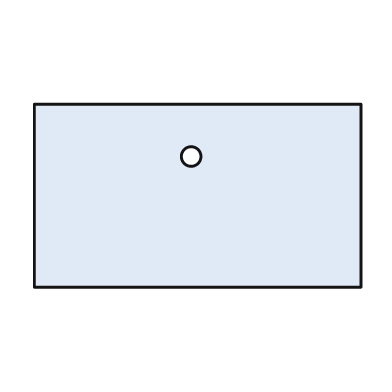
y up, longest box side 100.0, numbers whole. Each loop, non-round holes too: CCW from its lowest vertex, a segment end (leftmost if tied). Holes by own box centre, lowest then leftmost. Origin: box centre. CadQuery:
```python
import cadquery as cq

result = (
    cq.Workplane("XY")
    .moveTo(-50.0, -28.0)
    .lineTo(50.0, -28.0)
    .lineTo(50.0, 28.0)
    .lineTo(-50.0, 28.0)
    .close()
    .moveTo(-2.0, 12.0)
    .circle(3.0)
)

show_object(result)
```